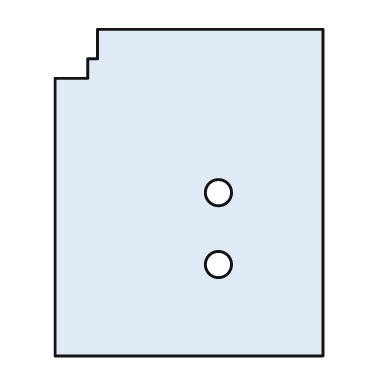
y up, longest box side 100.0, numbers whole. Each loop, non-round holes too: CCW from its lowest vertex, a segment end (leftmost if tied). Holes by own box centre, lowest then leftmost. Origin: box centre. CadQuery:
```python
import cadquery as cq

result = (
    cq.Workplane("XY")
    .moveTo(-41.0, -50.0)
    .lineTo(41.0, -50.0)
    .lineTo(41.0, 50.0)
    .lineTo(-28.0, 50.0)
    .lineTo(-28.0, 41.0)
    .lineTo(-31.0, 41.0)
    .lineTo(-31.0, 35.0)
    .lineTo(-41.0, 35.0)
    .close()
    .moveTo(9.0, -22.0)
    .circle(4.0)
    .moveTo(9.0, 0.0)
    .circle(4.0)
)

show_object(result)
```